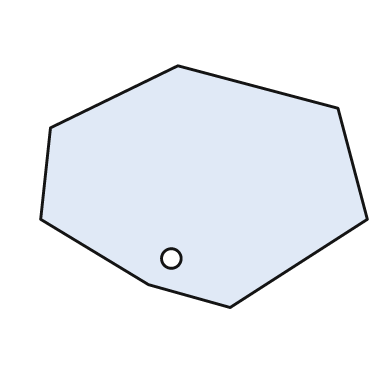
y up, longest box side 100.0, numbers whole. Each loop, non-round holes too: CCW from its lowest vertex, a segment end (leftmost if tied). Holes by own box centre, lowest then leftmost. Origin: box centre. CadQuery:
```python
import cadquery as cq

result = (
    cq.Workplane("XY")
    .moveTo(8.0, -37.0)
    .lineTo(50.0, -10.0)
    .lineTo(41.0, 24.0)
    .lineTo(-8.0, 37.0)
    .lineTo(-47.0, 18.0)
    .lineTo(-50.0, -10.0)
    .lineTo(-17.0, -30.0)
    .close()
    .moveTo(-10.0, -22.0)
    .circle(3.0)
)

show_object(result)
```